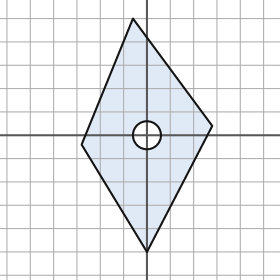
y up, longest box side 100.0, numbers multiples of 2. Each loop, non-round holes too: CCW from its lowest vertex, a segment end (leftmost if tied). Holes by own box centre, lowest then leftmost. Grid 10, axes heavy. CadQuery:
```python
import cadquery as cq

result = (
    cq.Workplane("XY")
    .moveTo(0.0, -50.0)
    .lineTo(28.0, 4.0)
    .lineTo(-6.0, 50.0)
    .lineTo(-28.0, -4.0)
    .close()
    .moveTo(0.0, 0.0)
    .circle(6.0)
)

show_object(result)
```